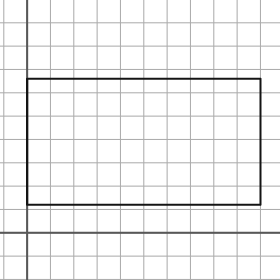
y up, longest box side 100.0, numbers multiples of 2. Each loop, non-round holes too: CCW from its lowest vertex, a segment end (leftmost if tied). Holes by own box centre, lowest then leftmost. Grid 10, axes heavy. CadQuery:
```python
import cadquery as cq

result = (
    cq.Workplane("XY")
    .moveTo(0.0, 12.0)
    .lineTo(100.0, 12.0)
    .lineTo(100.0, 66.0)
    .lineTo(0.0, 66.0)
    .close()
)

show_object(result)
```